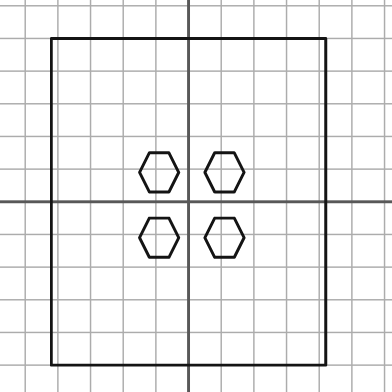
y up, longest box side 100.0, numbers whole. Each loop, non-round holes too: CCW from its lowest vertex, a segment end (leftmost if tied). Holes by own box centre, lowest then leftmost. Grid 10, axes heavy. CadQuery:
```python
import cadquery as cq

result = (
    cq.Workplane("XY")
    .moveTo(-42.0, -50.0)
    .lineTo(42.0, -50.0)
    .lineTo(42.0, 50.0)
    .lineTo(-42.0, 50.0)
    .close()
    .moveTo(-12.0, -17.0)
    .lineTo(-6.0, -17.0)
    .lineTo(-3.0, -11.0)
    .lineTo(-6.0, -5.0)
    .lineTo(-12.0, -5.0)
    .lineTo(-15.0, -11.0)
    .close()
    .moveTo(8.0, -17.0)
    .lineTo(14.0, -17.0)
    .lineTo(17.0, -11.0)
    .lineTo(14.0, -5.0)
    .lineTo(8.0, -5.0)
    .lineTo(5.0, -11.0)
    .close()
    .moveTo(-12.0, 3.0)
    .lineTo(-6.0, 3.0)
    .lineTo(-3.0, 9.0)
    .lineTo(-6.0, 15.0)
    .lineTo(-12.0, 15.0)
    .lineTo(-15.0, 9.0)
    .close()
    .moveTo(8.0, 3.0)
    .lineTo(14.0, 3.0)
    .lineTo(17.0, 9.0)
    .lineTo(14.0, 15.0)
    .lineTo(8.0, 15.0)
    .lineTo(5.0, 9.0)
    .close()
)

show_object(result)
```